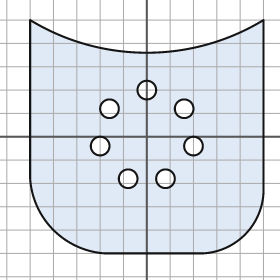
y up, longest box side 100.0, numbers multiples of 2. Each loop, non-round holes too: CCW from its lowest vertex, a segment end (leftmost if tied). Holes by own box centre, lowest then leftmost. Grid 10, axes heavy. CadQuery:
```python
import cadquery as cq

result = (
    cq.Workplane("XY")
    .moveTo(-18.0, -50.0)
    .lineTo(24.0, -50.0)
    .threePointArc((42.0, -42.0), (50.0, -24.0))
    .lineTo(50.0, 50.0)
    .threePointArc((0.0, 36.0), (-50.0, 50.0))
    .lineTo(-50.0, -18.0)
    .threePointArc((-40.0, -40.0), (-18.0, -50.0))
    .close()
    .moveTo(-8.0, -18.0)
    .circle(4.0)
    .moveTo(8.0, -18.0)
    .circle(4.0)
    .moveTo(-20.0, -4.0)
    .circle(4.0)
    .moveTo(20.0, -4.0)
    .circle(4.0)
    .moveTo(-16.0, 12.0)
    .circle(4.0)
    .moveTo(16.0, 12.0)
    .circle(4.0)
    .moveTo(0.0, 20.0)
    .circle(4.0)
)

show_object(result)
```